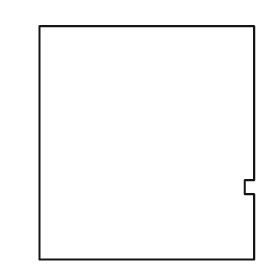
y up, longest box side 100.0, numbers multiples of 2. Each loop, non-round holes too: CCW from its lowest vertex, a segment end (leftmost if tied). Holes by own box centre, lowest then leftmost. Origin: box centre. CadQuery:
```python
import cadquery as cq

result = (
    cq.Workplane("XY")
    .moveTo(-46.0, -50.0)
    .lineTo(46.0, -50.0)
    .lineTo(46.0, -22.0)
    .lineTo(42.0, -22.0)
    .lineTo(42.0, -16.0)
    .lineTo(46.0, -16.0)
    .lineTo(46.0, 50.0)
    .lineTo(-46.0, 50.0)
    .close()
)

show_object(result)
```